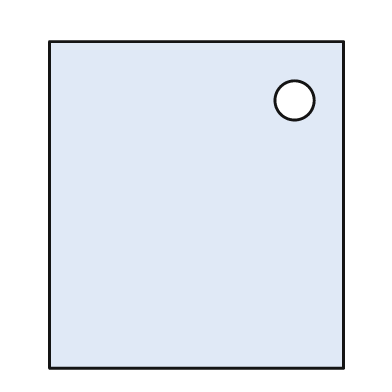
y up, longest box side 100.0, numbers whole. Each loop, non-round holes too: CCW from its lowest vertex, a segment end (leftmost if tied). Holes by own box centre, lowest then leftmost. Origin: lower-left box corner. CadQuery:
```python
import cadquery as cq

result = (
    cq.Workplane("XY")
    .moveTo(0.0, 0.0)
    .lineTo(90.0, 0.0)
    .lineTo(90.0, 100.0)
    .lineTo(0.0, 100.0)
    .close()
    .moveTo(75.0, 82.0)
    .circle(6.0)
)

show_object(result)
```